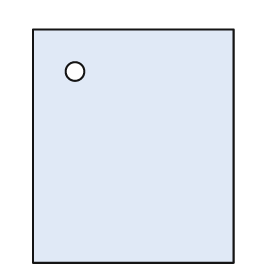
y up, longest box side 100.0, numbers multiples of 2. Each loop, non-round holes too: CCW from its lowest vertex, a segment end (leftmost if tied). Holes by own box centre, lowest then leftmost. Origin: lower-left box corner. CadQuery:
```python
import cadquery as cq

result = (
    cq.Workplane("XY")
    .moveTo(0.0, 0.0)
    .lineTo(86.0, 0.0)
    .lineTo(86.0, 100.0)
    .lineTo(0.0, 100.0)
    .close()
    .moveTo(18.0, 82.0)
    .circle(4.0)
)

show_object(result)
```